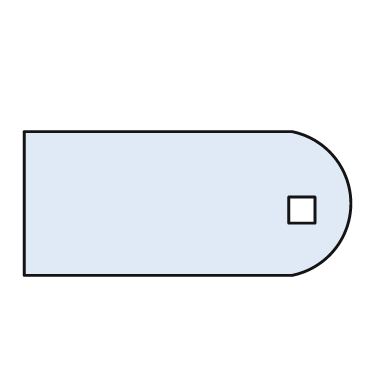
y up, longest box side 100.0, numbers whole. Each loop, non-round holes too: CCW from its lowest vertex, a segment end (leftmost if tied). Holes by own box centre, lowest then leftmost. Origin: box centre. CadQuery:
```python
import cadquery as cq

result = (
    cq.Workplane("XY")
    .moveTo(-50.0, -22.0)
    .lineTo(32.0, -22.0)
    .threePointArc((50.0, 0.0), (32.0, 22.0))
    .lineTo(-50.0, 22.0)
    .close()
    .moveTo(31.0, -6.0)
    .lineTo(39.0, -6.0)
    .lineTo(39.0, 2.0)
    .lineTo(31.0, 2.0)
    .close()
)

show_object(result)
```